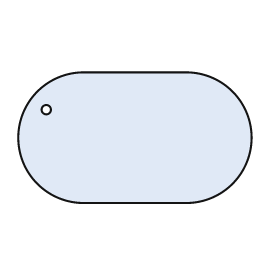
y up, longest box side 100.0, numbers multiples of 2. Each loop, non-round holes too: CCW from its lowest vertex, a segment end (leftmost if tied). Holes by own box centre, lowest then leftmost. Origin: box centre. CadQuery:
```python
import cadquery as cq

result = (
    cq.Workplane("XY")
    .moveTo(-22.0, -28.0)
    .lineTo(22.0, -28.0)
    .threePointArc((50.0, 0.0), (22.0, 28.0))
    .lineTo(-22.0, 28.0)
    .threePointArc((-50.0, 0.0), (-22.0, -28.0))
    .close()
    .moveTo(-38.0, 12.0)
    .circle(2.0)
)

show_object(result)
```